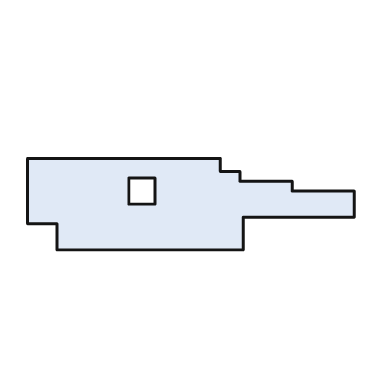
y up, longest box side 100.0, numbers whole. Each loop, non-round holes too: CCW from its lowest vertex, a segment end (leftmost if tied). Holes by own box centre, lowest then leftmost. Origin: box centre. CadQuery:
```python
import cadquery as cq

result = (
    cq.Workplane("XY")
    .moveTo(-41.0, -14.0)
    .lineTo(16.0, -14.0)
    .lineTo(16.0, -4.0)
    .lineTo(50.0, -4.0)
    .lineTo(50.0, 4.0)
    .lineTo(31.0, 4.0)
    .lineTo(31.0, 7.0)
    .lineTo(15.0, 7.0)
    .lineTo(15.0, 10.0)
    .lineTo(9.0, 10.0)
    .lineTo(9.0, 14.0)
    .lineTo(-50.0, 14.0)
    .lineTo(-50.0, -6.0)
    .lineTo(-41.0, -6.0)
    .close()
    .moveTo(-19.0, 0.0)
    .lineTo(-11.0, 0.0)
    .lineTo(-11.0, 8.0)
    .lineTo(-19.0, 8.0)
    .close()
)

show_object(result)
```